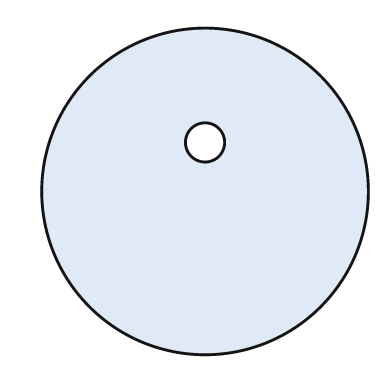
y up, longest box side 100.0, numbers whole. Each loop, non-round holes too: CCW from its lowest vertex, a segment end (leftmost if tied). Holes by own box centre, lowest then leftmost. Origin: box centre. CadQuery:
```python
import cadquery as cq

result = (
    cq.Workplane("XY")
    .moveTo(0.0, 0.0)
    .circle(50.0)
    .moveTo(0.0, 15.0)
    .circle(6.0)
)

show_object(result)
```